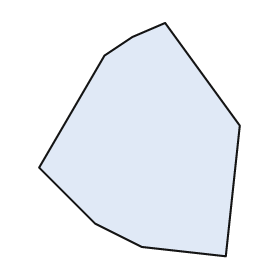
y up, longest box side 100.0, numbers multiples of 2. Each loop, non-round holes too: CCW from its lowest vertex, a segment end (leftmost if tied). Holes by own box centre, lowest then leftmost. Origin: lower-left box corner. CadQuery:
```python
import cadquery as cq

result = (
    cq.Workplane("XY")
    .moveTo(80.0, 0.0)
    .lineTo(86.0, 56.0)
    .lineTo(54.0, 100.0)
    .lineTo(40.0, 94.0)
    .lineTo(28.0, 86.0)
    .lineTo(0.0, 38.0)
    .lineTo(24.0, 14.0)
    .lineTo(44.0, 4.0)
    .close()
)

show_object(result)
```